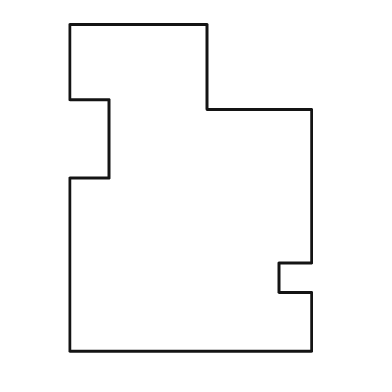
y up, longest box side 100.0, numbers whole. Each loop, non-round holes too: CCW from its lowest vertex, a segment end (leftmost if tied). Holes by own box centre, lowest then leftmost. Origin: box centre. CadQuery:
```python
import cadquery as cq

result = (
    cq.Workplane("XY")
    .moveTo(-37.0, -50.0)
    .lineTo(37.0, -50.0)
    .lineTo(37.0, -32.0)
    .lineTo(27.0, -32.0)
    .lineTo(27.0, -23.0)
    .lineTo(37.0, -23.0)
    .lineTo(37.0, 24.0)
    .lineTo(5.0, 24.0)
    .lineTo(5.0, 50.0)
    .lineTo(-37.0, 50.0)
    .lineTo(-37.0, 27.0)
    .lineTo(-25.0, 27.0)
    .lineTo(-25.0, 3.0)
    .lineTo(-37.0, 3.0)
    .close()
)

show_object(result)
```